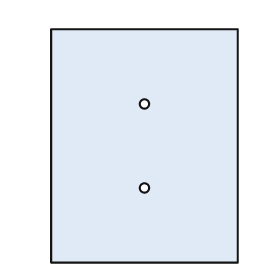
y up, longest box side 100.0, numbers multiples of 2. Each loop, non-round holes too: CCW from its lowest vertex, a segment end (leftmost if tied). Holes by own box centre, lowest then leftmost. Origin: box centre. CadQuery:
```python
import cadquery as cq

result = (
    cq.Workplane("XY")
    .moveTo(-40.0, -50.0)
    .lineTo(40.0, -50.0)
    .lineTo(40.0, 50.0)
    .lineTo(-40.0, 50.0)
    .close()
    .moveTo(0.0, -18.0)
    .circle(2.0)
    .moveTo(0.0, 18.0)
    .circle(2.0)
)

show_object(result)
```